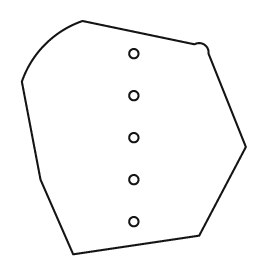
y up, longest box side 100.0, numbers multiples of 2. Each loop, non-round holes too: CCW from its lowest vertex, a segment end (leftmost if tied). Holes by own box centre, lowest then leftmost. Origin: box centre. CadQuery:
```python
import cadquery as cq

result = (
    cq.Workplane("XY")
    .moveTo(-26.0, -50.0)
    .lineTo(28.0, -42.0)
    .lineTo(48.0, -4.0)
    .lineTo(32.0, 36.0)
    .threePointArc((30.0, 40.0), (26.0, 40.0))
    .lineTo(-22.0, 50.0)
    .threePointArc((-38.0, 40.0), (-48.0, 24.0))
    .lineTo(-40.0, -18.0)
    .close()
    .moveTo(0.0, -36.0)
    .circle(2.0)
    .moveTo(0.0, -18.0)
    .circle(2.0)
    .moveTo(0.0, 0.0)
    .circle(2.0)
    .moveTo(0.0, 18.0)
    .circle(2.0)
    .moveTo(0.0, 36.0)
    .circle(2.0)
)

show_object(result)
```